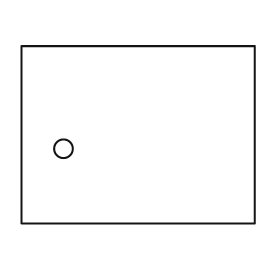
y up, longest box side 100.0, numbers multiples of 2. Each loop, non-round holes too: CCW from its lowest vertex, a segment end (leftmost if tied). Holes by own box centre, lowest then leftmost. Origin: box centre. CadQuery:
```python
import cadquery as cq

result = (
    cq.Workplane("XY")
    .moveTo(-50.0, -38.0)
    .lineTo(50.0, -38.0)
    .lineTo(50.0, 38.0)
    .lineTo(-50.0, 38.0)
    .close()
    .moveTo(-32.0, -6.0)
    .circle(4.0)
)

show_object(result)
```